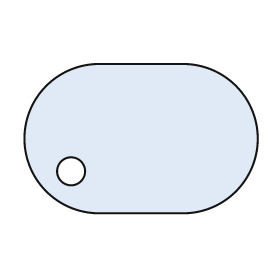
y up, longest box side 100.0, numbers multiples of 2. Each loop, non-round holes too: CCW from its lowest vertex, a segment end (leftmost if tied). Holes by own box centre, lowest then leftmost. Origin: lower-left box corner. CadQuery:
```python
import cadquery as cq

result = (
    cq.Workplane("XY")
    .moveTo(32.0, 0.0)
    .lineTo(68.0, 0.0)
    .threePointArc((100.0, 32.0), (68.0, 64.0))
    .lineTo(32.0, 64.0)
    .threePointArc((0.0, 32.0), (32.0, 0.0))
    .close()
    .moveTo(20.0, 18.0)
    .circle(6.0)
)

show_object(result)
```